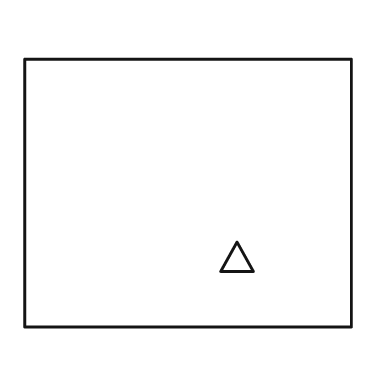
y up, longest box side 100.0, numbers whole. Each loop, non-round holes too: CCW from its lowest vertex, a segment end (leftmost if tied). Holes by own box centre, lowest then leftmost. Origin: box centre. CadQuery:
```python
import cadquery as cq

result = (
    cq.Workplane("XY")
    .moveTo(-50.0, -41.0)
    .lineTo(50.0, -41.0)
    .lineTo(50.0, 41.0)
    .lineTo(-50.0, 41.0)
    .close()
    .moveTo(10.0, -24.0)
    .lineTo(20.0, -24.0)
    .lineTo(15.0, -15.0)
    .close()
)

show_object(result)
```